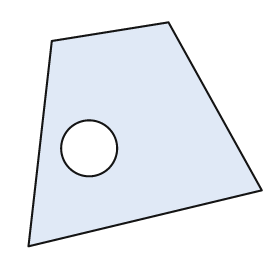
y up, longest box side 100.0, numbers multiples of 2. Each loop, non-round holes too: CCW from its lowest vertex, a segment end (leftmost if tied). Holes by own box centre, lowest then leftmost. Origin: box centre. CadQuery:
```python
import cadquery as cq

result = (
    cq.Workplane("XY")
    .moveTo(-50.0, -48.0)
    .lineTo(50.0, -24.0)
    .lineTo(10.0, 48.0)
    .lineTo(-40.0, 40.0)
    .close()
    .moveTo(-24.0, -6.0)
    .circle(12.0)
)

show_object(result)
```